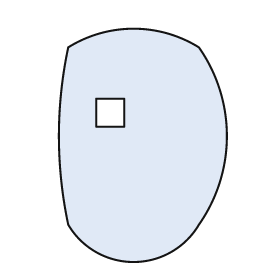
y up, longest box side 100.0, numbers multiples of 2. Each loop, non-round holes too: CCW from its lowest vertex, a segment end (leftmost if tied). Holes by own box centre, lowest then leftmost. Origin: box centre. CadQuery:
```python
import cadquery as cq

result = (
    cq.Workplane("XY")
    .moveTo(-32.0, -34.0)
    .threePointArc((-4.0, -50.0), (24.0, -34.0))
    .threePointArc((36.0, 4.0), (24.0, 42.0))
    .threePointArc((-4.0, 50.0), (-32.0, 42.0))
    .threePointArc((-36.0, 4.0), (-32.0, -34.0))
    .close()
    .moveTo(-20.0, 8.0)
    .lineTo(-8.0, 8.0)
    .lineTo(-8.0, 20.0)
    .lineTo(-20.0, 20.0)
    .close()
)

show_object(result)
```